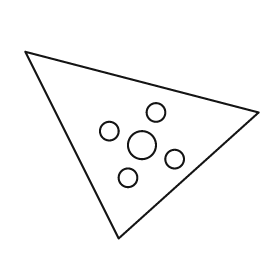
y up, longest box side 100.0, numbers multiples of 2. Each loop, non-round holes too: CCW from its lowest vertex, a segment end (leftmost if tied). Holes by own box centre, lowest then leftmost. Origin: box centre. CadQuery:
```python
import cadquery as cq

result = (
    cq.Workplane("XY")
    .moveTo(-10.0, -40.0)
    .lineTo(50.0, 14.0)
    .lineTo(-50.0, 40.0)
    .close()
    .moveTo(-6.0, -14.0)
    .circle(4.0)
    .moveTo(14.0, -6.0)
    .circle(4.0)
    .moveTo(0.0, 0.0)
    .circle(6.0)
    .moveTo(-14.0, 6.0)
    .circle(4.0)
    .moveTo(6.0, 14.0)
    .circle(4.0)
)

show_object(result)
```